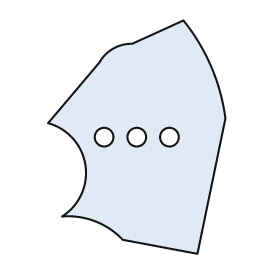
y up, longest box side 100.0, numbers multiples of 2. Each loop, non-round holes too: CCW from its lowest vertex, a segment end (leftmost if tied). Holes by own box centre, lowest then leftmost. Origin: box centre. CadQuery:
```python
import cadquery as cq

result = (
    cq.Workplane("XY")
    .moveTo(26.0, -50.0)
    .lineTo(38.0, 8.0)
    .threePointArc((32.0, 30.0), (20.0, 50.0))
    .lineTo(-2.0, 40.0)
    .threePointArc((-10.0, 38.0), (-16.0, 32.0))
    .lineTo(-38.0, 6.0)
    .threePointArc((-22.0, -12.0), (-32.0, -34.0))
    .threePointArc((-18.0, -36.0), (-6.0, -44.0))
    .close()
    .moveTo(-14.0, 0.0)
    .circle(4.0)
    .moveTo(0.0, 0.0)
    .circle(4.0)
    .moveTo(14.0, 0.0)
    .circle(4.0)
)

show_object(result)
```